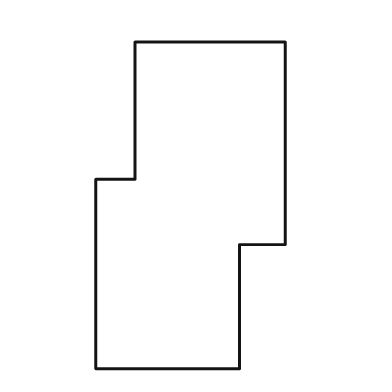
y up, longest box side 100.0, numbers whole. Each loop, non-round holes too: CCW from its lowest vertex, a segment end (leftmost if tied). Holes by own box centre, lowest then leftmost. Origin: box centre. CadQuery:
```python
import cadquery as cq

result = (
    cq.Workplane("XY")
    .moveTo(-29.0, -50.0)
    .lineTo(15.0, -50.0)
    .lineTo(15.0, -12.0)
    .lineTo(29.0, -12.0)
    .lineTo(29.0, 50.0)
    .lineTo(-17.0, 50.0)
    .lineTo(-17.0, 8.0)
    .lineTo(-29.0, 8.0)
    .close()
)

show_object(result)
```